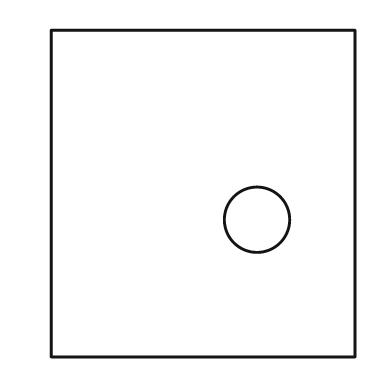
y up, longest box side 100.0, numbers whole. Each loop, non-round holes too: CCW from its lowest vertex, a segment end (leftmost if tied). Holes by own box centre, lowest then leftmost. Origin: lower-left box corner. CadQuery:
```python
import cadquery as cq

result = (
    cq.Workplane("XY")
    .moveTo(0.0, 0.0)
    .lineTo(93.0, 0.0)
    .lineTo(93.0, 100.0)
    .lineTo(0.0, 100.0)
    .close()
    .moveTo(63.0, 42.0)
    .circle(10.0)
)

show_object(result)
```